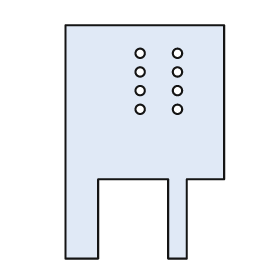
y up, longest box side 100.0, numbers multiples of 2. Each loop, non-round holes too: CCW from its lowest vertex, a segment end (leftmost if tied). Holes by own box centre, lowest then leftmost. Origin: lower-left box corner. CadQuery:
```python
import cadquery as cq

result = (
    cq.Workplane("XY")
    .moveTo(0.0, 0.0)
    .lineTo(14.0, 0.0)
    .lineTo(14.0, 34.0)
    .lineTo(44.0, 34.0)
    .lineTo(44.0, 0.0)
    .lineTo(52.0, 0.0)
    .lineTo(52.0, 34.0)
    .lineTo(68.0, 34.0)
    .lineTo(68.0, 100.0)
    .lineTo(0.0, 100.0)
    .close()
    .moveTo(32.0, 64.0)
    .circle(2.0)
    .moveTo(48.0, 64.0)
    .circle(2.0)
    .moveTo(32.0, 72.0)
    .circle(2.0)
    .moveTo(48.0, 72.0)
    .circle(2.0)
    .moveTo(32.0, 80.0)
    .circle(2.0)
    .moveTo(48.0, 80.0)
    .circle(2.0)
    .moveTo(32.0, 88.0)
    .circle(2.0)
    .moveTo(48.0, 88.0)
    .circle(2.0)
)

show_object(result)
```